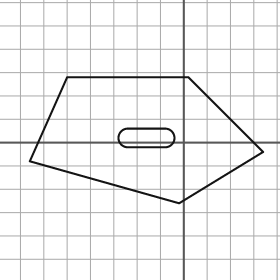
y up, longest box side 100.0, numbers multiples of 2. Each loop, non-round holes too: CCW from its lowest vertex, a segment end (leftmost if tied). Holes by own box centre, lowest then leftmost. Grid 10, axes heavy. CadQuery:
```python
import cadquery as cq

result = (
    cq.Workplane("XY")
    .moveTo(-2.0, -26.0)
    .lineTo(34.0, -4.0)
    .lineTo(2.0, 28.0)
    .lineTo(-50.0, 28.0)
    .lineTo(-66.0, -8.0)
    .close()
    .moveTo(-24.0, -2.0)
    .lineTo(-8.0, -2.0)
    .threePointArc((-4.0, 2.0), (-8.0, 6.0))
    .lineTo(-24.0, 6.0)
    .threePointArc((-28.0, 2.0), (-24.0, -2.0))
    .close()
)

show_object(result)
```